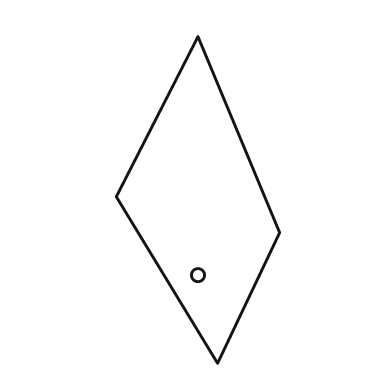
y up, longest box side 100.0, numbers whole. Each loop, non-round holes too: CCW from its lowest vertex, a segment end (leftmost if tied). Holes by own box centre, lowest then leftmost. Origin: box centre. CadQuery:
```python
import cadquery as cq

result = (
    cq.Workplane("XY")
    .moveTo(6.0, -50.0)
    .lineTo(25.0, -10.0)
    .lineTo(0.0, 50.0)
    .lineTo(-25.0, 1.0)
    .close()
    .moveTo(0.0, -23.0)
    .circle(2.0)
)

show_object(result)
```